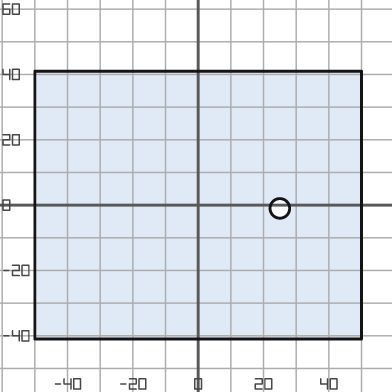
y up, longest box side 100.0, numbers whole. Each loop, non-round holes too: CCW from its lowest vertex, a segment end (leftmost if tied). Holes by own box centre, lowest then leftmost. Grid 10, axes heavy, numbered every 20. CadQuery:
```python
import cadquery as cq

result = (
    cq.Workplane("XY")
    .moveTo(-50.0, -41.0)
    .lineTo(50.0, -41.0)
    .lineTo(50.0, 41.0)
    .lineTo(-50.0, 41.0)
    .close()
    .moveTo(25.0, -1.0)
    .circle(3.0)
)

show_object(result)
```